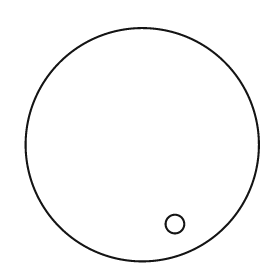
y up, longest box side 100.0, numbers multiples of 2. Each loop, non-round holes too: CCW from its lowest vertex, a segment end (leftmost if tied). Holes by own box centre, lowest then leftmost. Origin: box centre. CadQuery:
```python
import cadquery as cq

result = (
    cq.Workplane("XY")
    .moveTo(0.0, 0.0)
    .circle(50.0)
    .moveTo(14.0, -34.0)
    .circle(4.0)
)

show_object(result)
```